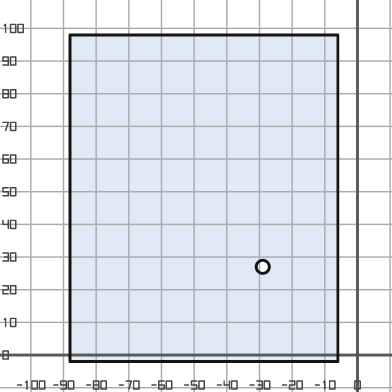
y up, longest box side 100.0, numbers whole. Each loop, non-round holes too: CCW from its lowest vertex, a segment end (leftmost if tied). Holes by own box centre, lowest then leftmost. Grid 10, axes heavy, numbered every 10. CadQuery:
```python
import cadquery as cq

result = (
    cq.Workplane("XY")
    .moveTo(-88.0, -2.0)
    .lineTo(-6.0, -2.0)
    .lineTo(-6.0, 98.0)
    .lineTo(-88.0, 98.0)
    .close()
    .moveTo(-29.0, 27.0)
    .circle(2.0)
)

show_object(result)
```